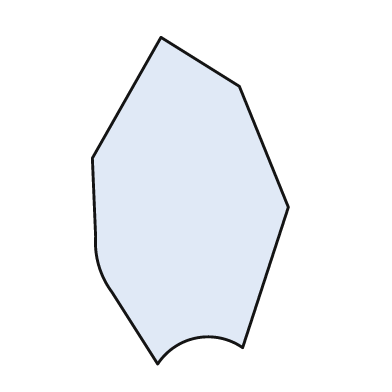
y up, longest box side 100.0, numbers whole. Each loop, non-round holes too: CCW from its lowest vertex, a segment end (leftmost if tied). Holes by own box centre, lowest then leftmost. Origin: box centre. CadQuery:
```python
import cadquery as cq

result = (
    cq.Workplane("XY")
    .moveTo(-10.0, -50.0)
    .threePointArc((2.0, -42.0), (16.0, -45.0))
    .lineTo(30.0, -2.0)
    .lineTo(15.0, 35.0)
    .lineTo(-9.0, 50.0)
    .lineTo(-30.0, 13.0)
    .lineTo(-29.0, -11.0)
    .threePointArc((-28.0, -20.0), (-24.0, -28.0))
    .close()
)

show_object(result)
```